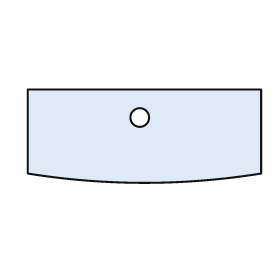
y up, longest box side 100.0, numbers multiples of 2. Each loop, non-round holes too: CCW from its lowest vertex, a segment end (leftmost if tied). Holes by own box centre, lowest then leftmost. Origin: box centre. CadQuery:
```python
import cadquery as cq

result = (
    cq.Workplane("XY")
    .moveTo(-50.0, -16.0)
    .threePointArc((0.0, -20.0), (50.0, -16.0))
    .lineTo(50.0, 20.0)
    .lineTo(-50.0, 20.0)
    .close()
    .moveTo(-2.0, 8.0)
    .circle(4.0)
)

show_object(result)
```